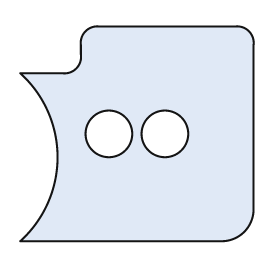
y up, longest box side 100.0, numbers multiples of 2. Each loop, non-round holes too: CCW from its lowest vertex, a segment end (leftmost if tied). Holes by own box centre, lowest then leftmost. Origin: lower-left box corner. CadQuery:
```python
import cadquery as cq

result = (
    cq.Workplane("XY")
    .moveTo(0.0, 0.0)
    .lineTo(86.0, 0.0)
    .threePointArc((96.0, 4.0), (100.0, 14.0))
    .lineTo(100.0, 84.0)
    .threePointArc((98.0, 90.0), (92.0, 92.0))
    .lineTo(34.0, 92.0)
    .threePointArc((28.0, 90.0), (26.0, 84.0))
    .lineTo(26.0, 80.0)
    .threePointArc((24.0, 74.0), (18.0, 72.0))
    .lineTo(0.0, 72.0)
    .threePointArc((16.0, 36.0), (0.0, 0.0))
    .close()
    .moveTo(38.0, 46.0)
    .circle(10.0)
    .moveTo(62.0, 46.0)
    .circle(10.0)
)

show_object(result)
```